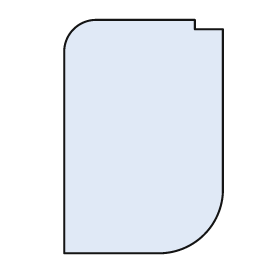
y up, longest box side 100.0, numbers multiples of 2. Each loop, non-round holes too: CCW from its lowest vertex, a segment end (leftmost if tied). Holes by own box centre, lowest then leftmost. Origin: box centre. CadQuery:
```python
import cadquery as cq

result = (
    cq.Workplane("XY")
    .moveTo(-34.0, -50.0)
    .lineTo(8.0, -50.0)
    .threePointArc((26.0, -42.0), (34.0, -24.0))
    .lineTo(34.0, 46.0)
    .lineTo(22.0, 46.0)
    .lineTo(22.0, 50.0)
    .lineTo(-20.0, 50.0)
    .threePointArc((-30.0, 46.0), (-34.0, 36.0))
    .close()
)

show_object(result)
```